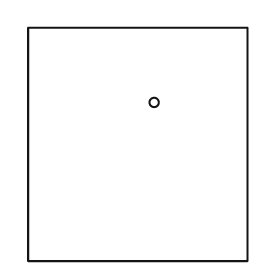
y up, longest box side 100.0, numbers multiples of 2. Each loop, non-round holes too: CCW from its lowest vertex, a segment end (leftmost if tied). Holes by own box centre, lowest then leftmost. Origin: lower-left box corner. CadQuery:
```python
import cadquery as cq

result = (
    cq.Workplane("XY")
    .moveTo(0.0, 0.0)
    .lineTo(94.0, 0.0)
    .lineTo(94.0, 100.0)
    .lineTo(0.0, 100.0)
    .close()
    .moveTo(54.0, 68.0)
    .circle(2.0)
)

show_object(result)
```